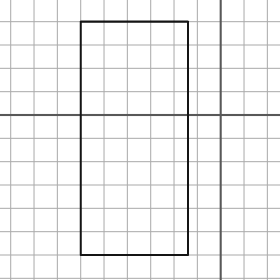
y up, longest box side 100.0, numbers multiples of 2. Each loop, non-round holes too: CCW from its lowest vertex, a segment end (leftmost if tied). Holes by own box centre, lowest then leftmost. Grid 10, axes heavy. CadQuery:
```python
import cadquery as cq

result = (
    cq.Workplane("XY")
    .moveTo(-60.0, -60.0)
    .lineTo(-14.0, -60.0)
    .lineTo(-14.0, 40.0)
    .lineTo(-60.0, 40.0)
    .close()
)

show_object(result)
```